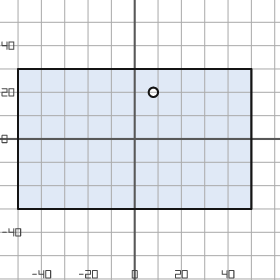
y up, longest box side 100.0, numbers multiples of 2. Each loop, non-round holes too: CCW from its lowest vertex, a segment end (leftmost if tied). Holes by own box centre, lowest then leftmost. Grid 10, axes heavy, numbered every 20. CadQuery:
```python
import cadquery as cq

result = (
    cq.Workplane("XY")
    .moveTo(-50.0, -30.0)
    .lineTo(50.0, -30.0)
    .lineTo(50.0, 30.0)
    .lineTo(-50.0, 30.0)
    .close()
    .moveTo(8.0, 20.0)
    .circle(2.0)
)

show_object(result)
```